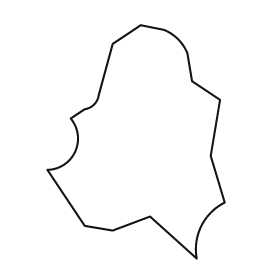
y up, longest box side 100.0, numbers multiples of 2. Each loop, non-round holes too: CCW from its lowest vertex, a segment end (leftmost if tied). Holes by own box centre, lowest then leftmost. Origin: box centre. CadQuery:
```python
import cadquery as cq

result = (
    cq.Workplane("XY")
    .moveTo(26.0, -50.0)
    .threePointArc((28.0, -36.0), (38.0, -26.0))
    .lineTo(32.0, -6.0)
    .lineTo(36.0, 18.0)
    .lineTo(24.0, 26.0)
    .lineTo(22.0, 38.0)
    .threePointArc((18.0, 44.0), (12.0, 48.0))
    .lineTo(2.0, 50.0)
    .lineTo(-10.0, 42.0)
    .lineTo(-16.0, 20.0)
    .threePointArc((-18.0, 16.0), (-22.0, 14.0))
    .lineTo(-28.0, 10.0)
    .threePointArc((-26.0, -4.0), (-38.0, -12.0))
    .lineTo(-22.0, -36.0)
    .lineTo(-10.0, -38.0)
    .lineTo(6.0, -32.0)
    .close()
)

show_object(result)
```